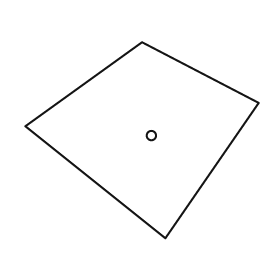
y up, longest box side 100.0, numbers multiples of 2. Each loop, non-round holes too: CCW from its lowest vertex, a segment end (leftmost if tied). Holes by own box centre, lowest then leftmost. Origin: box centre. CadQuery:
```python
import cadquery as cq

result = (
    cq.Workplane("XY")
    .moveTo(10.0, -42.0)
    .lineTo(50.0, 16.0)
    .lineTo(0.0, 42.0)
    .lineTo(-50.0, 6.0)
    .close()
    .moveTo(4.0, 2.0)
    .circle(2.0)
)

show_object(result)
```